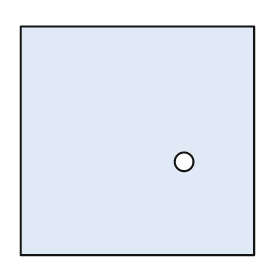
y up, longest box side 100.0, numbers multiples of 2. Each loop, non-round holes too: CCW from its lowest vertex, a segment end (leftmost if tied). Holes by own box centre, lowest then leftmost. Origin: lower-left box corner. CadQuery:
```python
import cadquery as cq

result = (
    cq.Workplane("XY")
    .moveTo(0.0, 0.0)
    .lineTo(100.0, 0.0)
    .lineTo(100.0, 98.0)
    .lineTo(0.0, 98.0)
    .close()
    .moveTo(70.0, 40.0)
    .circle(4.0)
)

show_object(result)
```